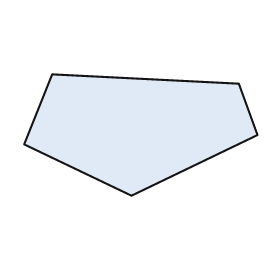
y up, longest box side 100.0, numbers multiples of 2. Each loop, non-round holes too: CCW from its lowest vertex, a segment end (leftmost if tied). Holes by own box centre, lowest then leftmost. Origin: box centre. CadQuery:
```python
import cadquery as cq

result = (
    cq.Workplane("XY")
    .moveTo(-4.0, -26.0)
    .lineTo(50.0, 0.0)
    .lineTo(42.0, 22.0)
    .lineTo(-38.0, 26.0)
    .lineTo(-50.0, -4.0)
    .close()
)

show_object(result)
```